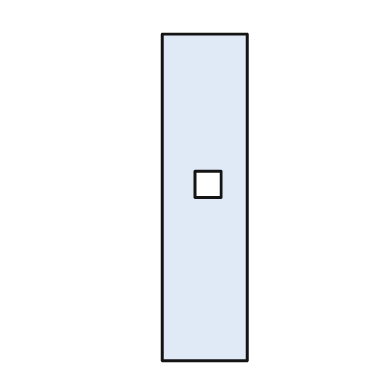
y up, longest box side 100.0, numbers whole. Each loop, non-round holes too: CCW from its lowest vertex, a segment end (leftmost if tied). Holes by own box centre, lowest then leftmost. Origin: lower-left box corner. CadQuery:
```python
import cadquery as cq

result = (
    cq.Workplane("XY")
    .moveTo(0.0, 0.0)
    .lineTo(26.0, 0.0)
    .lineTo(26.0, 100.0)
    .lineTo(0.0, 100.0)
    .close()
    .moveTo(10.0, 50.0)
    .lineTo(18.0, 50.0)
    .lineTo(18.0, 58.0)
    .lineTo(10.0, 58.0)
    .close()
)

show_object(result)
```